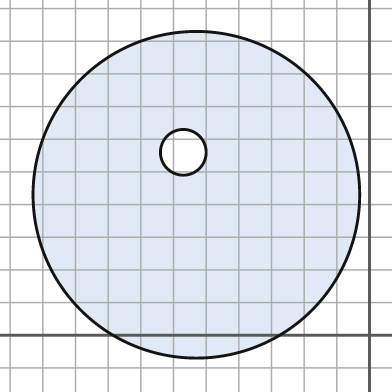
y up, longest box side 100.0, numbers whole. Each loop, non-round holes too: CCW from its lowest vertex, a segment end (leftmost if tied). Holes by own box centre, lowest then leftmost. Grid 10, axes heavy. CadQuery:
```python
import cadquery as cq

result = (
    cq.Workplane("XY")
    .moveTo(-53.0, 43.0)
    .circle(50.0)
    .moveTo(-57.0, 56.0)
    .circle(7.0)
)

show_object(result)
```